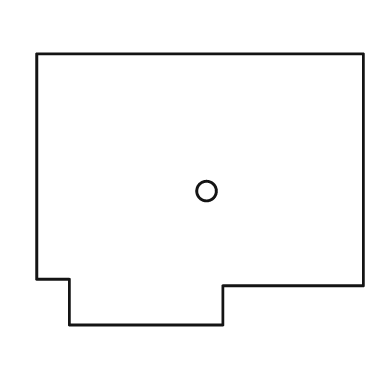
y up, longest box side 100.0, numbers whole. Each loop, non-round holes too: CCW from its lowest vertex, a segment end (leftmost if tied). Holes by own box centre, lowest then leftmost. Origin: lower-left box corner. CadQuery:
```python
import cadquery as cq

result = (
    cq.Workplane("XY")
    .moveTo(10.0, 0.0)
    .lineTo(57.0, 0.0)
    .lineTo(57.0, 12.0)
    .lineTo(100.0, 12.0)
    .lineTo(100.0, 83.0)
    .lineTo(0.0, 83.0)
    .lineTo(0.0, 14.0)
    .lineTo(10.0, 14.0)
    .close()
    .moveTo(52.0, 41.0)
    .circle(3.0)
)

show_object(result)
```